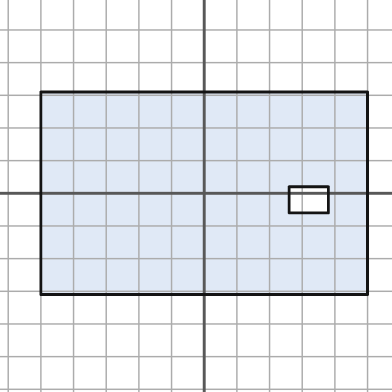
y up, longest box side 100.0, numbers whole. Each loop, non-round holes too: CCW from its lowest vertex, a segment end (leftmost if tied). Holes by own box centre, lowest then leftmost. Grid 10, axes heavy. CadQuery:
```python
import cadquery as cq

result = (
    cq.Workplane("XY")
    .moveTo(-50.0, -31.0)
    .lineTo(50.0, -31.0)
    .lineTo(50.0, 31.0)
    .lineTo(-50.0, 31.0)
    .close()
    .moveTo(26.0, -6.0)
    .lineTo(38.0, -6.0)
    .lineTo(38.0, 2.0)
    .lineTo(26.0, 2.0)
    .close()
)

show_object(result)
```